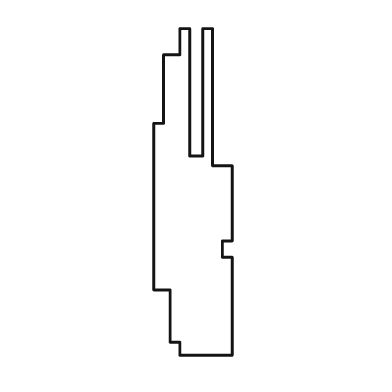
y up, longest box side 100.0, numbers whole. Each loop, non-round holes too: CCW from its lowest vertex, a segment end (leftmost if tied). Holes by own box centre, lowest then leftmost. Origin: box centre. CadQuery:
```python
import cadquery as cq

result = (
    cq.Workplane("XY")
    .moveTo(-4.0, -50.0)
    .lineTo(12.0, -50.0)
    .lineTo(12.0, -20.0)
    .lineTo(9.0, -20.0)
    .lineTo(9.0, -15.0)
    .lineTo(12.0, -15.0)
    .lineTo(12.0, 8.0)
    .lineTo(6.0, 8.0)
    .lineTo(6.0, 50.0)
    .lineTo(3.0, 50.0)
    .lineTo(3.0, 11.0)
    .lineTo(-1.0, 11.0)
    .lineTo(-1.0, 50.0)
    .lineTo(-4.0, 50.0)
    .lineTo(-4.0, 42.0)
    .lineTo(-9.0, 42.0)
    .lineTo(-9.0, 21.0)
    .lineTo(-12.0, 21.0)
    .lineTo(-12.0, -30.0)
    .lineTo(-7.0, -30.0)
    .lineTo(-7.0, -46.0)
    .lineTo(-4.0, -46.0)
    .close()
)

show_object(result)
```